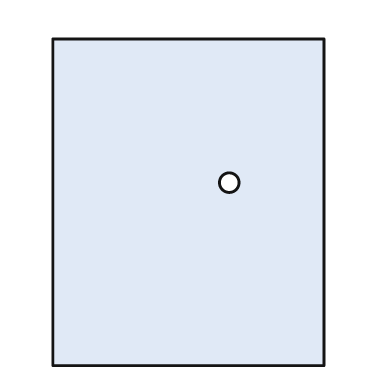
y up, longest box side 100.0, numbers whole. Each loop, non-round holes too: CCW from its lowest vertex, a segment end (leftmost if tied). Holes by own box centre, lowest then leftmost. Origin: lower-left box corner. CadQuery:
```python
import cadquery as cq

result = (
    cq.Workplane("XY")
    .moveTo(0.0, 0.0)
    .lineTo(83.0, 0.0)
    .lineTo(83.0, 100.0)
    .lineTo(0.0, 100.0)
    .close()
    .moveTo(54.0, 56.0)
    .circle(3.0)
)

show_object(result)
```